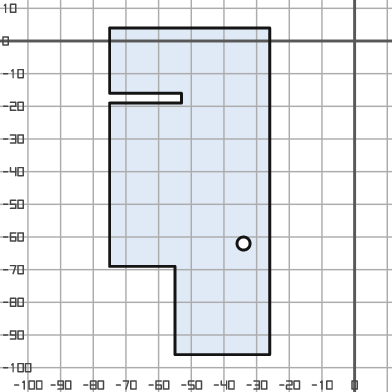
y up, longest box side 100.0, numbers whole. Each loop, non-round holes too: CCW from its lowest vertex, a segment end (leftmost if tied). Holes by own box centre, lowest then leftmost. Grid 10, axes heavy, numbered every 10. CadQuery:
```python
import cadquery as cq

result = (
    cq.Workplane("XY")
    .moveTo(-55.0, -96.0)
    .lineTo(-26.0, -96.0)
    .lineTo(-26.0, 4.0)
    .lineTo(-75.0, 4.0)
    .lineTo(-75.0, -16.0)
    .lineTo(-53.0, -16.0)
    .lineTo(-53.0, -19.0)
    .lineTo(-75.0, -19.0)
    .lineTo(-75.0, -69.0)
    .lineTo(-55.0, -69.0)
    .close()
    .moveTo(-34.0, -62.0)
    .circle(2.0)
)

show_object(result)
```